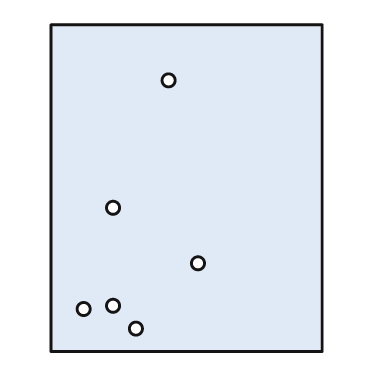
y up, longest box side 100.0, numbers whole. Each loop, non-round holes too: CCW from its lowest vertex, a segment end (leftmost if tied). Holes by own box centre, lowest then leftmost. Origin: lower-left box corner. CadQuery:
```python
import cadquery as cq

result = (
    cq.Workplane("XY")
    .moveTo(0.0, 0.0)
    .lineTo(83.0, 0.0)
    .lineTo(83.0, 100.0)
    .lineTo(0.0, 100.0)
    .close()
    .moveTo(26.0, 7.0)
    .circle(2.0)
    .moveTo(10.0, 13.0)
    .circle(2.0)
    .moveTo(19.0, 14.0)
    .circle(2.0)
    .moveTo(45.0, 27.0)
    .circle(2.0)
    .moveTo(19.0, 44.0)
    .circle(2.0)
    .moveTo(36.0, 83.0)
    .circle(2.0)
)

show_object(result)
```